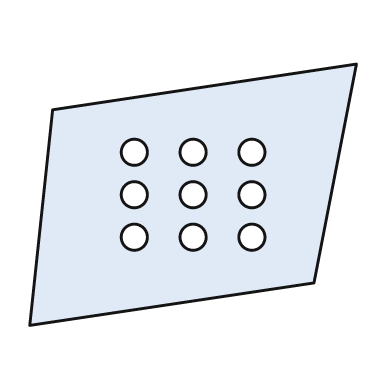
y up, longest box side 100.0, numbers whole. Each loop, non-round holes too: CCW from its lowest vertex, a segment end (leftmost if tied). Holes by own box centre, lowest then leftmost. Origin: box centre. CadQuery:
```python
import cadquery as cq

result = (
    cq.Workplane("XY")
    .moveTo(-50.0, -40.0)
    .lineTo(37.0, -27.0)
    .lineTo(50.0, 40.0)
    .lineTo(-43.0, 26.0)
    .close()
    .moveTo(-18.0, -13.0)
    .circle(4.0)
    .moveTo(0.0, -13.0)
    .circle(4.0)
    .moveTo(18.0, -13.0)
    .circle(4.0)
    .moveTo(-18.0, 0.0)
    .circle(4.0)
    .moveTo(0.0, 0.0)
    .circle(4.0)
    .moveTo(18.0, 0.0)
    .circle(4.0)
    .moveTo(-18.0, 13.0)
    .circle(4.0)
    .moveTo(0.0, 13.0)
    .circle(4.0)
    .moveTo(18.0, 13.0)
    .circle(4.0)
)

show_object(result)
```